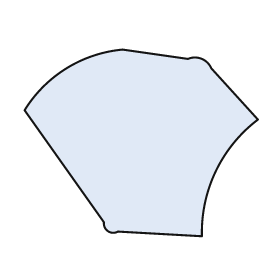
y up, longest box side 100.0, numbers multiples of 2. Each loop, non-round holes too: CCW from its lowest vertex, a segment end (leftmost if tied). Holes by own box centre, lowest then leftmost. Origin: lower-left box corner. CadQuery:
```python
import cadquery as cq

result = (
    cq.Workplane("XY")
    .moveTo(76.0, 0.0)
    .threePointArc((82.0, 28.0), (100.0, 50.0))
    .lineTo(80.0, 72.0)
    .threePointArc((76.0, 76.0), (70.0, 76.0))
    .lineTo(42.0, 80.0)
    .threePointArc((18.0, 72.0), (0.0, 54.0))
    .lineTo(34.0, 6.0)
    .threePointArc((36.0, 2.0), (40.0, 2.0))
    .close()
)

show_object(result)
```